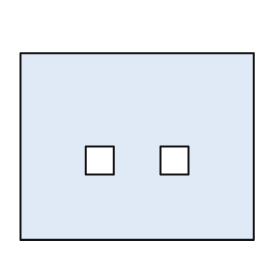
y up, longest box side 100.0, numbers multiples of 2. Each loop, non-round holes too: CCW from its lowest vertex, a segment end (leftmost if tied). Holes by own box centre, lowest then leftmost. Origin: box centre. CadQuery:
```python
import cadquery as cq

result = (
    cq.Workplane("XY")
    .moveTo(-50.0, -40.0)
    .lineTo(50.0, -40.0)
    .lineTo(50.0, 40.0)
    .lineTo(-50.0, 40.0)
    .close()
    .moveTo(-22.0, -12.0)
    .lineTo(-10.0, -12.0)
    .lineTo(-10.0, 0.0)
    .lineTo(-22.0, 0.0)
    .close()
    .moveTo(10.0, -12.0)
    .lineTo(22.0, -12.0)
    .lineTo(22.0, 0.0)
    .lineTo(10.0, 0.0)
    .close()
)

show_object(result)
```